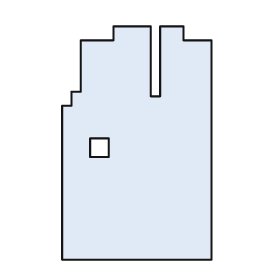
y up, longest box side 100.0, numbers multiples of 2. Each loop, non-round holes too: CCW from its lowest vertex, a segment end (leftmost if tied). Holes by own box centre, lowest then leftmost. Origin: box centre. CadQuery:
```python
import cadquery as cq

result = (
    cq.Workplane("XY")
    .moveTo(-32.0, -50.0)
    .lineTo(32.0, -50.0)
    .lineTo(32.0, 44.0)
    .lineTo(20.0, 44.0)
    .lineTo(20.0, 50.0)
    .lineTo(10.0, 50.0)
    .lineTo(10.0, 20.0)
    .lineTo(6.0, 20.0)
    .lineTo(6.0, 50.0)
    .lineTo(-10.0, 50.0)
    .lineTo(-10.0, 44.0)
    .lineTo(-24.0, 44.0)
    .lineTo(-24.0, 22.0)
    .lineTo(-28.0, 22.0)
    .lineTo(-28.0, 16.0)
    .lineTo(-32.0, 16.0)
    .close()
    .moveTo(-20.0, -6.0)
    .lineTo(-12.0, -6.0)
    .lineTo(-12.0, 2.0)
    .lineTo(-20.0, 2.0)
    .close()
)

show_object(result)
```